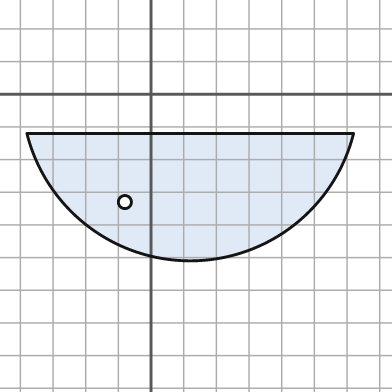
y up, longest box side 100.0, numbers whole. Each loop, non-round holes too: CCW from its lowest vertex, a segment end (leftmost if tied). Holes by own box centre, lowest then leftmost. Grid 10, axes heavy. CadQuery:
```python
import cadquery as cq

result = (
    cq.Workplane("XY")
    .moveTo(-38.0, -12.0)
    .threePointArc((12.0, -51.0), (62.0, -12.0))
    .close()
    .moveTo(-8.0, -33.0)
    .circle(2.0)
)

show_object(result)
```